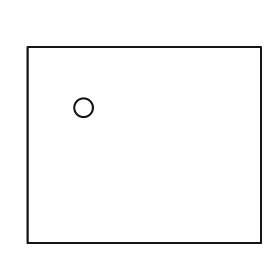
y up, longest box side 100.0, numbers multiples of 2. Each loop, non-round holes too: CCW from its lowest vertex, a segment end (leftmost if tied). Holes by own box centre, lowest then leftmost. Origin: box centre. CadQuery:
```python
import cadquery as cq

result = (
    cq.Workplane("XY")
    .moveTo(-50.0, -42.0)
    .lineTo(50.0, -42.0)
    .lineTo(50.0, 42.0)
    .lineTo(-50.0, 42.0)
    .close()
    .moveTo(-26.0, 16.0)
    .circle(4.0)
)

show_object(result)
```